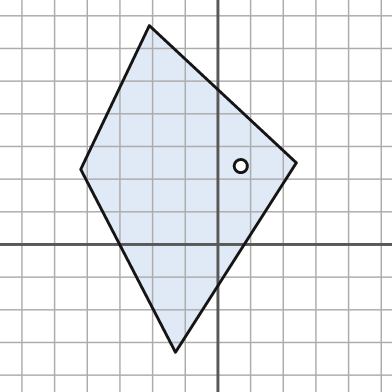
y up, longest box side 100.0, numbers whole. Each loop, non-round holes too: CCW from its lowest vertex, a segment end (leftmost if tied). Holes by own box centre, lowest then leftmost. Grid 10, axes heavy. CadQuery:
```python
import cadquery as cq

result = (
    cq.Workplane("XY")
    .moveTo(-13.0, -33.0)
    .lineTo(24.0, 25.0)
    .lineTo(-21.0, 67.0)
    .lineTo(-42.0, 23.0)
    .close()
    .moveTo(7.0, 24.0)
    .circle(2.0)
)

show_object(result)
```